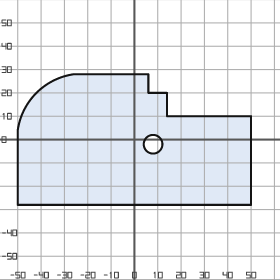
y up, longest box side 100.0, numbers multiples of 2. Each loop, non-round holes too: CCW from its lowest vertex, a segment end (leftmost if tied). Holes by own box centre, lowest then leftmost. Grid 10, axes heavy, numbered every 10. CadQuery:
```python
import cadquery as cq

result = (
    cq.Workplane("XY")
    .moveTo(-50.0, -28.0)
    .lineTo(50.0, -28.0)
    .lineTo(50.0, 10.0)
    .lineTo(14.0, 10.0)
    .lineTo(14.0, 20.0)
    .lineTo(6.0, 20.0)
    .lineTo(6.0, 28.0)
    .lineTo(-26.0, 28.0)
    .threePointArc((-42.0, 20.0), (-50.0, 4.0))
    .close()
    .moveTo(8.0, -2.0)
    .circle(4.0)
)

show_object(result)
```